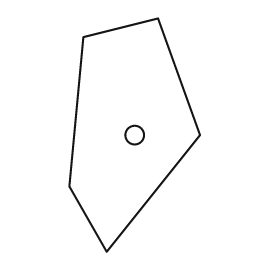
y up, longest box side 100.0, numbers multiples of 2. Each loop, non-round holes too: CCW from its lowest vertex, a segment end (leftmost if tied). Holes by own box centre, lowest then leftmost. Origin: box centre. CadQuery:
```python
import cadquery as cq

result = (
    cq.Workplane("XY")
    .moveTo(-12.0, -50.0)
    .lineTo(28.0, 0.0)
    .lineTo(10.0, 50.0)
    .lineTo(-22.0, 42.0)
    .lineTo(-28.0, -22.0)
    .close()
    .moveTo(0.0, 0.0)
    .circle(4.0)
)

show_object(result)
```